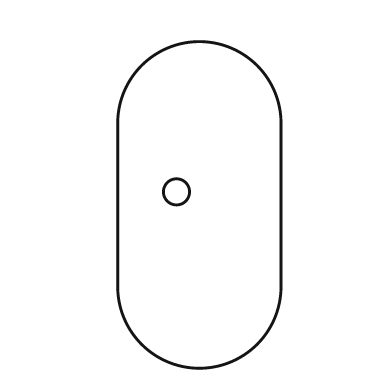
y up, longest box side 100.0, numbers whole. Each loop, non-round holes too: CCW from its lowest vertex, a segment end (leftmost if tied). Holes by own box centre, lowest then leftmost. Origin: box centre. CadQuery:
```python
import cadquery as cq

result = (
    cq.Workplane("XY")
    .moveTo(-25.0, -25.0)
    .threePointArc((0.0, -50.0), (25.0, -25.0))
    .lineTo(25.0, 25.0)
    .threePointArc((0.0, 50.0), (-25.0, 25.0))
    .close()
    .moveTo(-7.0, 4.0)
    .circle(4.0)
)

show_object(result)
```